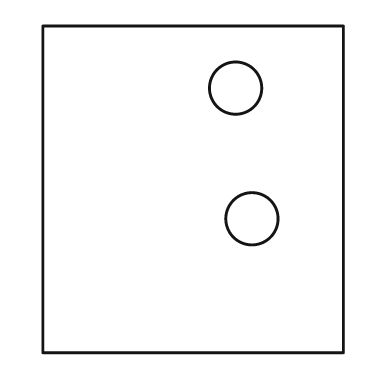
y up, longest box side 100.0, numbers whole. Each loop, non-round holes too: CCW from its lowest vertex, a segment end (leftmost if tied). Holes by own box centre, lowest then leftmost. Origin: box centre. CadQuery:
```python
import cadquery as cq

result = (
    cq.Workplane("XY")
    .moveTo(-46.0, -50.0)
    .lineTo(46.0, -50.0)
    .lineTo(46.0, 50.0)
    .lineTo(-46.0, 50.0)
    .close()
    .moveTo(18.0, -9.0)
    .circle(8.0)
    .moveTo(13.0, 31.0)
    .circle(8.0)
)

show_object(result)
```